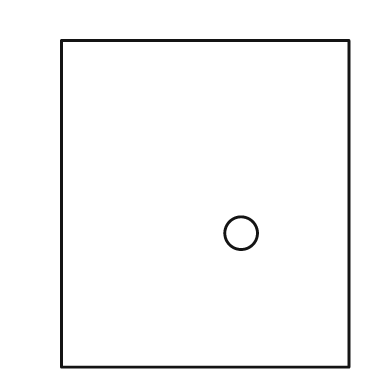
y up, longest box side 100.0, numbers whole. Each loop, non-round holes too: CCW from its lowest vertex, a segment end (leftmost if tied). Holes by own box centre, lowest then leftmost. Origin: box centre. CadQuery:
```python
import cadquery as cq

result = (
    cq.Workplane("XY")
    .moveTo(-44.0, -50.0)
    .lineTo(44.0, -50.0)
    .lineTo(44.0, 50.0)
    .lineTo(-44.0, 50.0)
    .close()
    .moveTo(11.0, -9.0)
    .circle(5.0)
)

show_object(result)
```